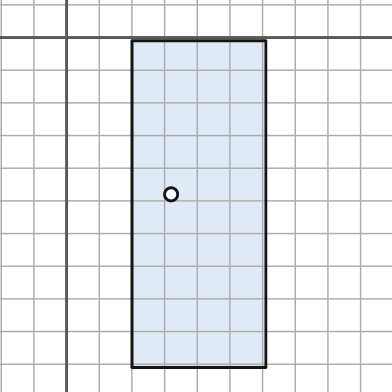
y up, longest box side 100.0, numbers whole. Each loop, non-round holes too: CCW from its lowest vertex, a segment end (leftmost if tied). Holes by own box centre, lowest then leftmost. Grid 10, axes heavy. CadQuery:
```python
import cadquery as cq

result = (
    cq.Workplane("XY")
    .moveTo(20.0, -101.0)
    .lineTo(61.0, -101.0)
    .lineTo(61.0, -1.0)
    .lineTo(20.0, -1.0)
    .close()
    .moveTo(32.0, -48.0)
    .circle(2.0)
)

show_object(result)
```